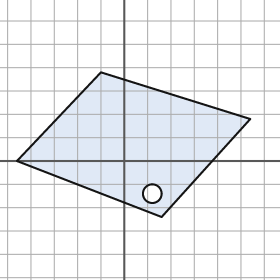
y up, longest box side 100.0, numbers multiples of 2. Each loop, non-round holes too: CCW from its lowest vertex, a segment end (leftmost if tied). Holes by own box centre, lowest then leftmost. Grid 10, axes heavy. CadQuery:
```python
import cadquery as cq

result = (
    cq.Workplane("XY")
    .moveTo(16.0, -24.0)
    .lineTo(54.0, 18.0)
    .lineTo(-10.0, 38.0)
    .lineTo(-46.0, 0.0)
    .close()
    .moveTo(12.0, -14.0)
    .circle(4.0)
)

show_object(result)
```